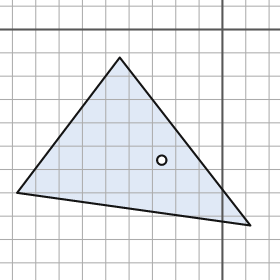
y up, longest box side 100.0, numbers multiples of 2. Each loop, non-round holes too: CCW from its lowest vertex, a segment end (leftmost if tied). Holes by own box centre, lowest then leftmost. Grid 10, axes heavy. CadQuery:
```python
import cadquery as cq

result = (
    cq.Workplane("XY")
    .moveTo(12.0, -84.0)
    .lineTo(-44.0, -12.0)
    .lineTo(-88.0, -70.0)
    .close()
    .moveTo(-26.0, -56.0)
    .circle(2.0)
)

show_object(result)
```